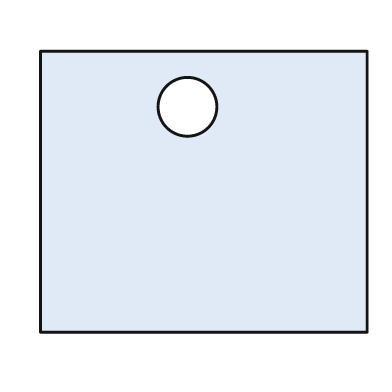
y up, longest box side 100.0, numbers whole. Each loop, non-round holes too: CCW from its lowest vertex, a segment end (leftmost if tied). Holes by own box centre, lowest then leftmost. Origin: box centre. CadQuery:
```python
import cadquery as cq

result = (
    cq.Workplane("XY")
    .moveTo(-50.0, -43.0)
    .lineTo(50.0, -43.0)
    .lineTo(50.0, 43.0)
    .lineTo(-50.0, 43.0)
    .close()
    .moveTo(-5.0, 26.0)
    .circle(9.0)
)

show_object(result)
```